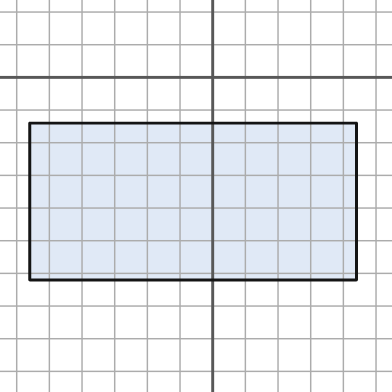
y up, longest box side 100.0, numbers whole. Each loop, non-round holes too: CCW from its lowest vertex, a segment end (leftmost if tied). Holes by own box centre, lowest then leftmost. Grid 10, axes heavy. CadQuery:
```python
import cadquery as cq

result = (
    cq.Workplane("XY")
    .moveTo(-56.0, -62.0)
    .lineTo(44.0, -62.0)
    .lineTo(44.0, -14.0)
    .lineTo(-56.0, -14.0)
    .close()
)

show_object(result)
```